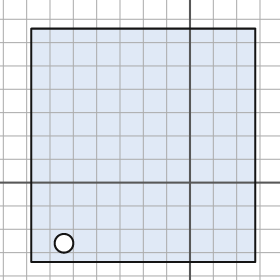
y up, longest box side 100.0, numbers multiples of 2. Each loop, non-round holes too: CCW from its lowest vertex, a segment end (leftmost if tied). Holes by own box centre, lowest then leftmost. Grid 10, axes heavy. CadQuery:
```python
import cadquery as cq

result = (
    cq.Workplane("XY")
    .moveTo(-68.0, -34.0)
    .lineTo(28.0, -34.0)
    .lineTo(28.0, 66.0)
    .lineTo(-68.0, 66.0)
    .close()
    .moveTo(-54.0, -26.0)
    .circle(4.0)
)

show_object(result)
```